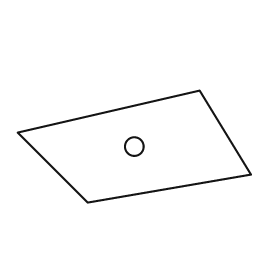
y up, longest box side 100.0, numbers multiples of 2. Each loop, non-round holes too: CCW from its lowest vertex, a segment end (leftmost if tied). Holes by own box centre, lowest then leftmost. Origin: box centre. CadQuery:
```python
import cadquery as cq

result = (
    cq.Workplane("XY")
    .moveTo(-20.0, -24.0)
    .lineTo(50.0, -12.0)
    .lineTo(28.0, 24.0)
    .lineTo(-50.0, 6.0)
    .close()
    .moveTo(0.0, 0.0)
    .circle(4.0)
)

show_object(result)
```